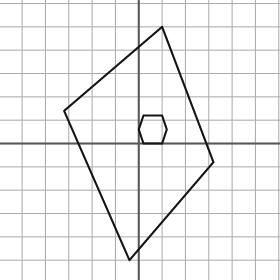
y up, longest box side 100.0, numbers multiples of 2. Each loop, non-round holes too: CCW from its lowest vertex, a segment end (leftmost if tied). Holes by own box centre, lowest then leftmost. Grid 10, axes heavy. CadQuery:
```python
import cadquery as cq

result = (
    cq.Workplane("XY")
    .moveTo(-4.0, -50.0)
    .lineTo(32.0, -8.0)
    .lineTo(10.0, 50.0)
    .lineTo(-32.0, 14.0)
    .close()
    .moveTo(2.0, 0.0)
    .lineTo(10.0, 0.0)
    .lineTo(12.0, 6.0)
    .lineTo(10.0, 12.0)
    .lineTo(2.0, 12.0)
    .lineTo(0.0, 6.0)
    .close()
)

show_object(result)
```